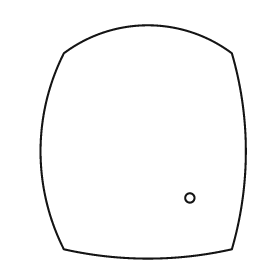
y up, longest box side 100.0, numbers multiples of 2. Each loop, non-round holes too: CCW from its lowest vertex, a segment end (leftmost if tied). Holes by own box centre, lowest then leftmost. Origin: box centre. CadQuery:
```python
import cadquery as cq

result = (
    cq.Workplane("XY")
    .moveTo(-34.0, -46.0)
    .threePointArc((2.0, -50.0), (38.0, -46.0))
    .threePointArc((44.0, -4.0), (38.0, 38.0))
    .threePointArc((2.0, 50.0), (-34.0, 38.0))
    .threePointArc((-44.0, -4.0), (-34.0, -46.0))
    .close()
    .moveTo(20.0, -24.0)
    .circle(2.0)
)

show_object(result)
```